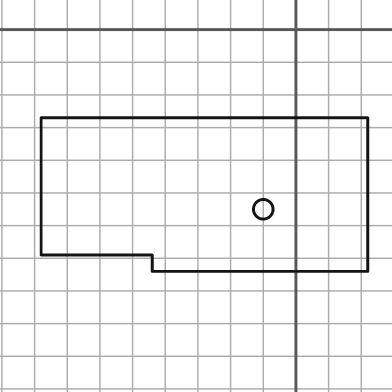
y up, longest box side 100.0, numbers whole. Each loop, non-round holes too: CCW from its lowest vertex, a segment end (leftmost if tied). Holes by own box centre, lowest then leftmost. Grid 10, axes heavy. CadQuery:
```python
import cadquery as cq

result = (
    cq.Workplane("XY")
    .moveTo(-44.0, -74.0)
    .lineTo(22.0, -74.0)
    .lineTo(22.0, -27.0)
    .lineTo(-78.0, -27.0)
    .lineTo(-78.0, -69.0)
    .lineTo(-44.0, -69.0)
    .close()
    .moveTo(-10.0, -55.0)
    .circle(3.0)
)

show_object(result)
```